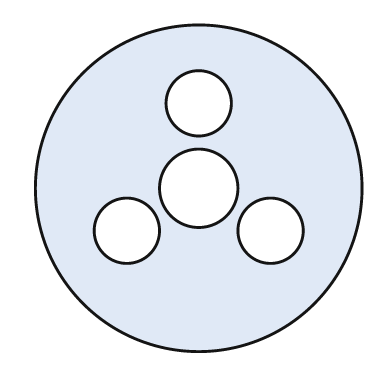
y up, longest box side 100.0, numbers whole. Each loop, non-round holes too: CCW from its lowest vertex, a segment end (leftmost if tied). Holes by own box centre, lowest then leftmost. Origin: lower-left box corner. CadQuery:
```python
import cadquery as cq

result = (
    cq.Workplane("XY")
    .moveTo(50.0, 50.0)
    .circle(50.0)
    .moveTo(28.0, 37.0)
    .circle(10.0)
    .moveTo(72.0, 37.0)
    .circle(10.0)
    .moveTo(50.0, 50.0)
    .circle(12.0)
    .moveTo(50.0, 76.0)
    .circle(10.0)
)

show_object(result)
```